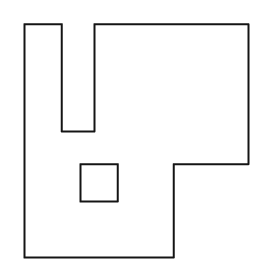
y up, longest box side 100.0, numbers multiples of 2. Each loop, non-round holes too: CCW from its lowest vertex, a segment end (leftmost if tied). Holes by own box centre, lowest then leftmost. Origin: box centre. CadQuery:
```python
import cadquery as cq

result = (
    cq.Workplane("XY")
    .moveTo(-48.0, -50.0)
    .lineTo(16.0, -50.0)
    .lineTo(16.0, -10.0)
    .lineTo(48.0, -10.0)
    .lineTo(48.0, 50.0)
    .lineTo(-18.0, 50.0)
    .lineTo(-18.0, 4.0)
    .lineTo(-32.0, 4.0)
    .lineTo(-32.0, 50.0)
    .lineTo(-48.0, 50.0)
    .close()
    .moveTo(-24.0, -26.0)
    .lineTo(-8.0, -26.0)
    .lineTo(-8.0, -10.0)
    .lineTo(-24.0, -10.0)
    .close()
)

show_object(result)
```